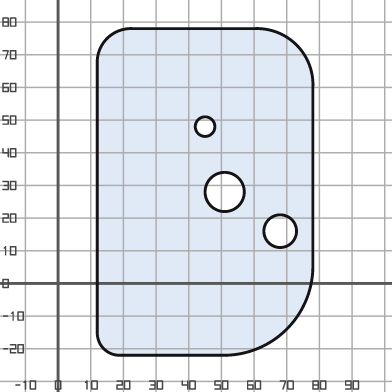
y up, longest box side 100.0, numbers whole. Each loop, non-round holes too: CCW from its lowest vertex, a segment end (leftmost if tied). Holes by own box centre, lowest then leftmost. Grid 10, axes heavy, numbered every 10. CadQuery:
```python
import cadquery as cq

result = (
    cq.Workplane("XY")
    .moveTo(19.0, -22.0)
    .lineTo(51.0, -22.0)
    .threePointArc((70.0, -14.0), (78.0, 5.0))
    .lineTo(78.0, 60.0)
    .threePointArc((73.0, 73.0), (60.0, 78.0))
    .lineTo(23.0, 78.0)
    .threePointArc((15.0, 75.0), (12.0, 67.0))
    .lineTo(12.0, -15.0)
    .threePointArc((14.0, -20.0), (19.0, -22.0))
    .close()
    .moveTo(68.0, 16.0)
    .circle(5.0)
    .moveTo(51.0, 28.0)
    .circle(6.0)
    .moveTo(45.0, 48.0)
    .circle(3.0)
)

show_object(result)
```